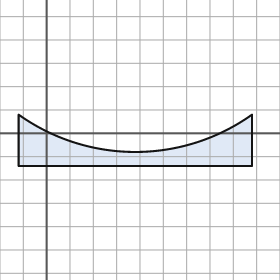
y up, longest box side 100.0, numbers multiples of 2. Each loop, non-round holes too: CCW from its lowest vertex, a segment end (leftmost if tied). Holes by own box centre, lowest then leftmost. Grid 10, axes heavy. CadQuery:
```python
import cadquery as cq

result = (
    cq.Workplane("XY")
    .moveTo(-12.0, -14.0)
    .lineTo(88.0, -14.0)
    .lineTo(88.0, 8.0)
    .threePointArc((38.0, -8.0), (-12.0, 8.0))
    .close()
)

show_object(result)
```